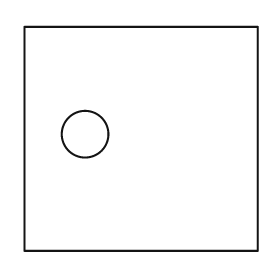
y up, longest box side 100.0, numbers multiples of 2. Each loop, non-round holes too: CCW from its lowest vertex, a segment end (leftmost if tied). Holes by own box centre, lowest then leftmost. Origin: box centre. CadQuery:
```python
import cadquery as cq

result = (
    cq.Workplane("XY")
    .moveTo(-50.0, -48.0)
    .lineTo(50.0, -48.0)
    .lineTo(50.0, 48.0)
    .lineTo(-50.0, 48.0)
    .close()
    .moveTo(-24.0, 2.0)
    .circle(10.0)
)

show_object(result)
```